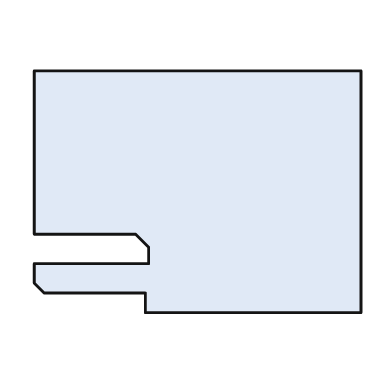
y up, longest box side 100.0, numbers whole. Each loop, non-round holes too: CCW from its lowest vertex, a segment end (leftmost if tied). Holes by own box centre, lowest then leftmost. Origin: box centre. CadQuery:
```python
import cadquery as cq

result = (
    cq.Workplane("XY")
    .moveTo(-16.0, -37.0)
    .lineTo(50.0, -37.0)
    .lineTo(50.0, 37.0)
    .lineTo(-50.0, 37.0)
    .lineTo(-50.0, -13.0)
    .lineTo(-19.0, -13.0)
    .lineTo(-15.0, -17.0)
    .lineTo(-15.0, -22.0)
    .lineTo(-50.0, -22.0)
    .lineTo(-50.0, -28.0)
    .lineTo(-47.0, -31.0)
    .lineTo(-16.0, -31.0)
    .close()
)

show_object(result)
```